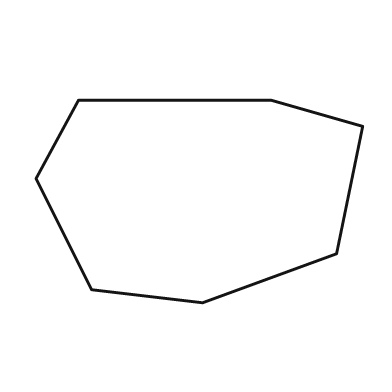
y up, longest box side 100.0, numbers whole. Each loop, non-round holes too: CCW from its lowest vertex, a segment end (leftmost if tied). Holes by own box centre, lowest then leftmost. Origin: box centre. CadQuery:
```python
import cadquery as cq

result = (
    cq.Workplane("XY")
    .moveTo(1.0, -31.0)
    .lineTo(42.0, -16.0)
    .lineTo(50.0, 23.0)
    .lineTo(22.0, 31.0)
    .lineTo(-37.0, 31.0)
    .lineTo(-50.0, 7.0)
    .lineTo(-33.0, -27.0)
    .close()
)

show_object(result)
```